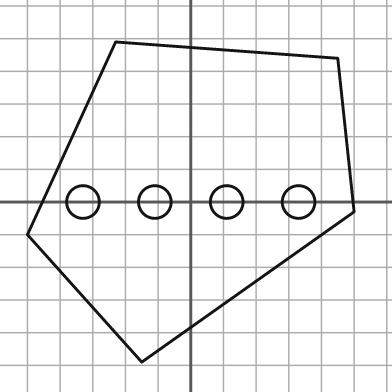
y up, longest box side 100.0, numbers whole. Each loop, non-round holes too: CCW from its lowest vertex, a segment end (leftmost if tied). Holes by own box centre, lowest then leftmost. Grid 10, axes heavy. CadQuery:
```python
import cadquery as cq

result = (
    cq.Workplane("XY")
    .moveTo(-15.0, -49.0)
    .lineTo(50.0, -3.0)
    .lineTo(45.0, 44.0)
    .lineTo(-23.0, 49.0)
    .lineTo(-50.0, -10.0)
    .close()
    .moveTo(-33.0, 0.0)
    .circle(5.0)
    .moveTo(-11.0, 0.0)
    .circle(5.0)
    .moveTo(11.0, 0.0)
    .circle(5.0)
    .moveTo(33.0, 0.0)
    .circle(5.0)
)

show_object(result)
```